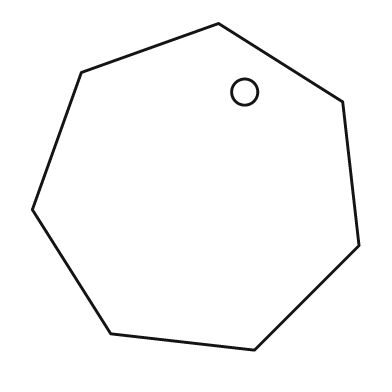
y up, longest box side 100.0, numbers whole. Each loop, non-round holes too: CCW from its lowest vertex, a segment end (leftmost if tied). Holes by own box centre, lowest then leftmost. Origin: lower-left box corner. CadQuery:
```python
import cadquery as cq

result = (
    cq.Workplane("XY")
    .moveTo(68.0, 0.0)
    .lineTo(100.0, 32.0)
    .lineTo(95.0, 76.0)
    .lineTo(57.0, 100.0)
    .lineTo(15.0, 85.0)
    .lineTo(0.0, 43.0)
    .lineTo(24.0, 5.0)
    .close()
    .moveTo(65.0, 79.0)
    .circle(4.0)
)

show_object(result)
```